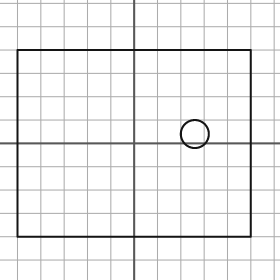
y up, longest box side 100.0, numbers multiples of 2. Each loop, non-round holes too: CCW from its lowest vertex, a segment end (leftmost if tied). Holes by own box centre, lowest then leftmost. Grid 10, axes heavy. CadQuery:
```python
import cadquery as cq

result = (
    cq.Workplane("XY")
    .moveTo(-50.0, -40.0)
    .lineTo(50.0, -40.0)
    .lineTo(50.0, 40.0)
    .lineTo(-50.0, 40.0)
    .close()
    .moveTo(26.0, 4.0)
    .circle(6.0)
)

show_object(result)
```